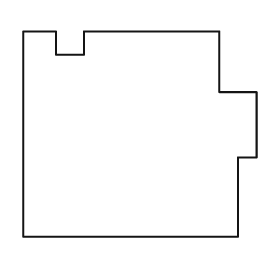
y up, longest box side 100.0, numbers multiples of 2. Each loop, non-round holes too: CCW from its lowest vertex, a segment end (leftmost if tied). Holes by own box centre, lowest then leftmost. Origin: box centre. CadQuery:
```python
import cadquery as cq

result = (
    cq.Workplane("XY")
    .moveTo(-50.0, -44.0)
    .lineTo(42.0, -44.0)
    .lineTo(42.0, -10.0)
    .lineTo(50.0, -10.0)
    .lineTo(50.0, 18.0)
    .lineTo(34.0, 18.0)
    .lineTo(34.0, 44.0)
    .lineTo(-24.0, 44.0)
    .lineTo(-24.0, 34.0)
    .lineTo(-36.0, 34.0)
    .lineTo(-36.0, 44.0)
    .lineTo(-50.0, 44.0)
    .close()
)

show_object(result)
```